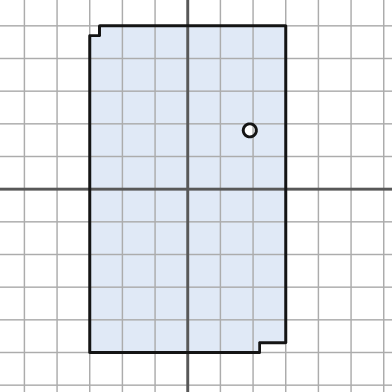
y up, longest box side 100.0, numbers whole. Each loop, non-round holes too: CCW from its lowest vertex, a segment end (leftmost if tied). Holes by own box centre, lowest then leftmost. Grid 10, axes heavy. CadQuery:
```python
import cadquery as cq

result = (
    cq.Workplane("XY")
    .moveTo(-30.0, -50.0)
    .lineTo(22.0, -50.0)
    .lineTo(22.0, -47.0)
    .lineTo(30.0, -47.0)
    .lineTo(30.0, 50.0)
    .lineTo(-27.0, 50.0)
    .lineTo(-27.0, 47.0)
    .lineTo(-30.0, 47.0)
    .close()
    .moveTo(19.0, 18.0)
    .circle(2.0)
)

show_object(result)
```